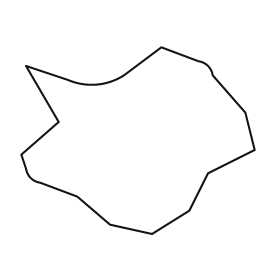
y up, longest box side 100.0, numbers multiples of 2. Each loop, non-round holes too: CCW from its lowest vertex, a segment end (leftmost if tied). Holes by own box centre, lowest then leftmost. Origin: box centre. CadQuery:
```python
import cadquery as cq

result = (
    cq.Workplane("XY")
    .moveTo(6.0, -40.0)
    .lineTo(22.0, -30.0)
    .lineTo(30.0, -14.0)
    .lineTo(50.0, -4.0)
    .lineTo(46.0, 12.0)
    .lineTo(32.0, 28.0)
    .threePointArc((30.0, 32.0), (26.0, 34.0))
    .lineTo(10.0, 40.0)
    .lineTo(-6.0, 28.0)
    .threePointArc((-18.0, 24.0), (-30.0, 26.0))
    .lineTo(-48.0, 32.0)
    .lineTo(-34.0, 8.0)
    .lineTo(-50.0, -6.0)
    .lineTo(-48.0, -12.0)
    .threePointArc((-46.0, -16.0), (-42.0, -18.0))
    .lineTo(-26.0, -24.0)
    .lineTo(-12.0, -36.0)
    .close()
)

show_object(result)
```